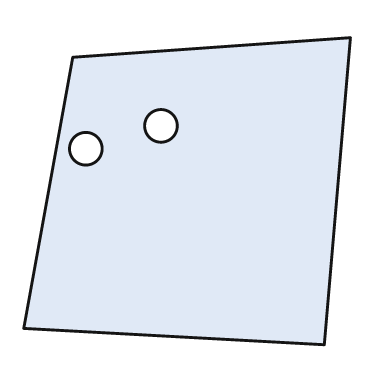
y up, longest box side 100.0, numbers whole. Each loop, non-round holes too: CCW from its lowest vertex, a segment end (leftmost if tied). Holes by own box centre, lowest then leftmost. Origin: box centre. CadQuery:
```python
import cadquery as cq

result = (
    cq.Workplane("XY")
    .moveTo(42.0, -47.0)
    .lineTo(50.0, 47.0)
    .lineTo(-35.0, 41.0)
    .lineTo(-50.0, -42.0)
    .close()
    .moveTo(-31.0, 13.0)
    .circle(5.0)
    .moveTo(-8.0, 20.0)
    .circle(5.0)
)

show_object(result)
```